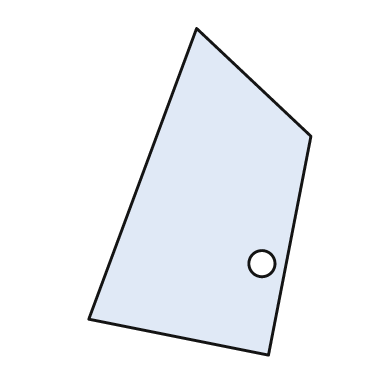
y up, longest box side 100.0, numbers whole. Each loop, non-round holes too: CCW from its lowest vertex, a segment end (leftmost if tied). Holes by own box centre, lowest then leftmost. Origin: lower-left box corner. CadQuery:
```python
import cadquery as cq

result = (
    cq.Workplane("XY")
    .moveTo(55.0, 0.0)
    .lineTo(68.0, 67.0)
    .lineTo(33.0, 100.0)
    .lineTo(0.0, 11.0)
    .close()
    .moveTo(53.0, 28.0)
    .circle(4.0)
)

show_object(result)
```